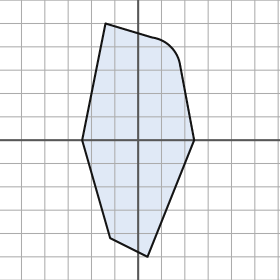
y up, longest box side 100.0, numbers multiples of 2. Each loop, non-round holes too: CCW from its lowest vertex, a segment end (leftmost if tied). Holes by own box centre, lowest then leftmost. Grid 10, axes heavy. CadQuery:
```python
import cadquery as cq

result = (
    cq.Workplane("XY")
    .moveTo(4.0, -50.0)
    .lineTo(24.0, 0.0)
    .lineTo(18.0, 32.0)
    .threePointArc((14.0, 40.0), (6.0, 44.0))
    .lineTo(-14.0, 50.0)
    .lineTo(-24.0, 0.0)
    .lineTo(-12.0, -42.0)
    .close()
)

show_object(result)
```